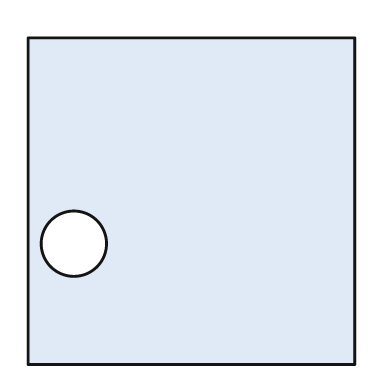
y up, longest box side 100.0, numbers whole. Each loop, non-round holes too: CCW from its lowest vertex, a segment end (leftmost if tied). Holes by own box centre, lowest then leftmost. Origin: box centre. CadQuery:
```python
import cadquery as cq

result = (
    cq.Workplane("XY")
    .moveTo(-50.0, -50.0)
    .lineTo(50.0, -50.0)
    .lineTo(50.0, 50.0)
    .lineTo(-50.0, 50.0)
    .close()
    .moveTo(-36.0, -13.0)
    .circle(10.0)
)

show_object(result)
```